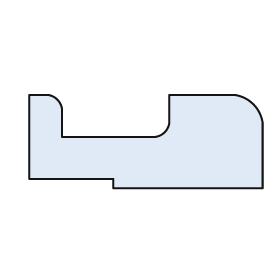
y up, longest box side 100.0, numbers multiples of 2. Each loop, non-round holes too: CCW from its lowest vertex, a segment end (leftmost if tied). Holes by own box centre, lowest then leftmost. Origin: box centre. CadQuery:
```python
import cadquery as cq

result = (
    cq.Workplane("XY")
    .moveTo(-14.0, -20.0)
    .lineTo(50.0, -20.0)
    .lineTo(50.0, 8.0)
    .threePointArc((46.0, 16.0), (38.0, 20.0))
    .lineTo(10.0, 20.0)
    .lineTo(10.0, 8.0)
    .threePointArc((8.0, 4.0), (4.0, 2.0))
    .lineTo(-36.0, 2.0)
    .lineTo(-36.0, 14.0)
    .threePointArc((-38.0, 18.0), (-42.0, 20.0))
    .lineTo(-50.0, 20.0)
    .lineTo(-50.0, -16.0)
    .lineTo(-14.0, -16.0)
    .close()
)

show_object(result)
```